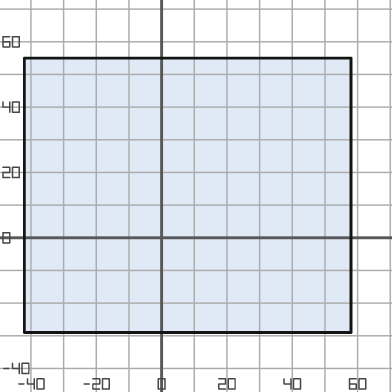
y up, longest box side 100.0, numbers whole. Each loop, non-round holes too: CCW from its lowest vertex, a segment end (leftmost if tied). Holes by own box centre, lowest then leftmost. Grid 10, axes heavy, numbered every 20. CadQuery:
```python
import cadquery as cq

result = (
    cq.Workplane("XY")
    .moveTo(-42.0, -29.0)
    .lineTo(58.0, -29.0)
    .lineTo(58.0, 55.0)
    .lineTo(-42.0, 55.0)
    .close()
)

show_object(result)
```